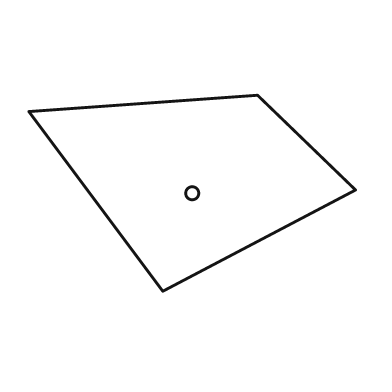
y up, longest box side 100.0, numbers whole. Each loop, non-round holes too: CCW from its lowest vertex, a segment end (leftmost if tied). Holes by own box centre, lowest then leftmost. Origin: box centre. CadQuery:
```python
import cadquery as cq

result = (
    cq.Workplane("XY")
    .moveTo(-9.0, -30.0)
    .lineTo(50.0, 1.0)
    .lineTo(20.0, 30.0)
    .lineTo(-50.0, 25.0)
    .close()
    .moveTo(0.0, 0.0)
    .circle(2.0)
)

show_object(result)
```